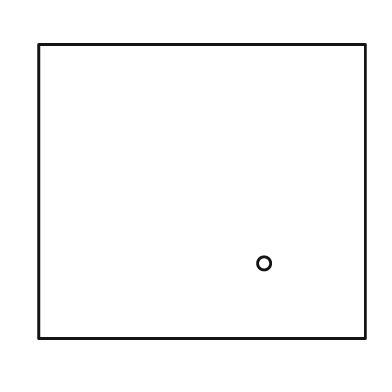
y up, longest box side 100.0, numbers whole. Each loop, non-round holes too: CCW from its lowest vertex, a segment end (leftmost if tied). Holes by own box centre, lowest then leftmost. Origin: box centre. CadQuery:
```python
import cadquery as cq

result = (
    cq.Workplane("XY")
    .moveTo(-50.0, -45.0)
    .lineTo(50.0, -45.0)
    .lineTo(50.0, 45.0)
    .lineTo(-50.0, 45.0)
    .close()
    .moveTo(19.0, -22.0)
    .circle(2.0)
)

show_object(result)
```